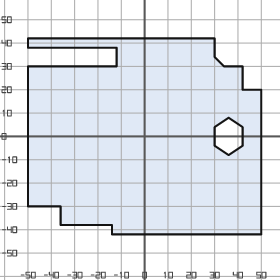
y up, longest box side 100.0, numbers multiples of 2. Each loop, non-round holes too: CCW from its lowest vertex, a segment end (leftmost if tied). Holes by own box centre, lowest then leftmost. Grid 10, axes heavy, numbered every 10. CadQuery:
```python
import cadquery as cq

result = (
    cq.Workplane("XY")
    .moveTo(-14.0, -42.0)
    .lineTo(50.0, -42.0)
    .lineTo(50.0, 20.0)
    .lineTo(42.0, 20.0)
    .lineTo(42.0, 30.0)
    .lineTo(34.0, 30.0)
    .lineTo(30.0, 34.0)
    .lineTo(30.0, 42.0)
    .lineTo(-50.0, 42.0)
    .lineTo(-50.0, 38.0)
    .lineTo(-12.0, 38.0)
    .lineTo(-12.0, 30.0)
    .lineTo(-50.0, 30.0)
    .lineTo(-50.0, -30.0)
    .lineTo(-36.0, -30.0)
    .lineTo(-36.0, -38.0)
    .lineTo(-14.0, -38.0)
    .close()
    .moveTo(36.0, -8.0)
    .lineTo(42.0, -4.0)
    .lineTo(42.0, 4.0)
    .lineTo(36.0, 8.0)
    .lineTo(30.0, 4.0)
    .lineTo(30.0, -4.0)
    .close()
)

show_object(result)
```